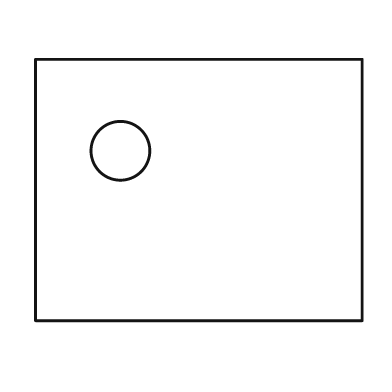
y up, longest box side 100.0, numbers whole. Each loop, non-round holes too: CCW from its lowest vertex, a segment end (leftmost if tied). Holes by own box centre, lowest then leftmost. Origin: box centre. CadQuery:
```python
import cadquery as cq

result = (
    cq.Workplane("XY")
    .moveTo(-50.0, -40.0)
    .lineTo(50.0, -40.0)
    .lineTo(50.0, 40.0)
    .lineTo(-50.0, 40.0)
    .close()
    .moveTo(-24.0, 12.0)
    .circle(9.0)
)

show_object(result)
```